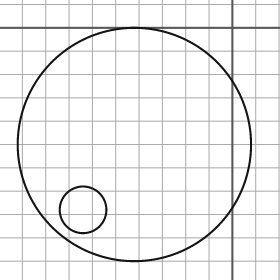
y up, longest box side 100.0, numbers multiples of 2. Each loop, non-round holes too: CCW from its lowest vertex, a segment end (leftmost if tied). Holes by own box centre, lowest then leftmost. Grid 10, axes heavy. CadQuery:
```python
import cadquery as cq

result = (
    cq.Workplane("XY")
    .moveTo(-42.0, -50.0)
    .circle(50.0)
    .moveTo(-64.0, -78.0)
    .circle(10.0)
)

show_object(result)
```